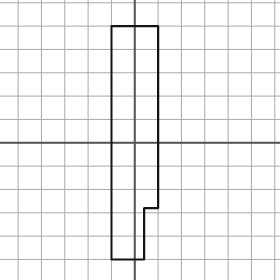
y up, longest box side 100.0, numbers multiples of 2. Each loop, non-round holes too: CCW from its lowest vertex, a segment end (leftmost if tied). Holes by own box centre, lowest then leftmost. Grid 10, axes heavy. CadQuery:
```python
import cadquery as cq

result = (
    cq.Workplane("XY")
    .moveTo(-10.0, -50.0)
    .lineTo(4.0, -50.0)
    .lineTo(4.0, -28.0)
    .lineTo(10.0, -28.0)
    .lineTo(10.0, 50.0)
    .lineTo(-10.0, 50.0)
    .close()
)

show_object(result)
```